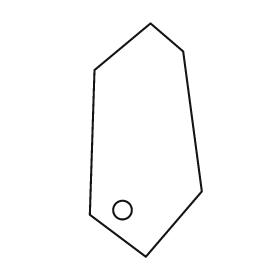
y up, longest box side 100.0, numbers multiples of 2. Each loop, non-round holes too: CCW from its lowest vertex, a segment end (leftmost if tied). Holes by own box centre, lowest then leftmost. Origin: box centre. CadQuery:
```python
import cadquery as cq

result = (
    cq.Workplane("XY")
    .moveTo(0.0, -50.0)
    .lineTo(24.0, -22.0)
    .lineTo(16.0, 38.0)
    .lineTo(2.0, 50.0)
    .lineTo(-22.0, 30.0)
    .lineTo(-24.0, -32.0)
    .close()
    .moveTo(-10.0, -30.0)
    .circle(4.0)
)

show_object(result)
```